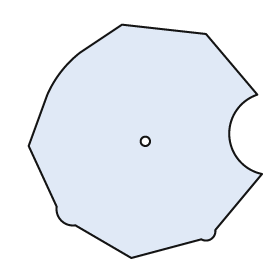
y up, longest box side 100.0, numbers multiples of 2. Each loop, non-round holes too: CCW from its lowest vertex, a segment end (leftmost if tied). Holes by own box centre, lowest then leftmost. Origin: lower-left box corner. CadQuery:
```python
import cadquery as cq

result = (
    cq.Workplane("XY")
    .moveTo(44.0, 0.0)
    .lineTo(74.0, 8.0)
    .threePointArc((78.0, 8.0), (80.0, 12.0))
    .lineTo(100.0, 36.0)
    .threePointArc((86.0, 52.0), (98.0, 70.0))
    .lineTo(76.0, 96.0)
    .lineTo(40.0, 100.0)
    .lineTo(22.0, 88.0)
    .threePointArc((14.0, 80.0), (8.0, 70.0))
    .lineTo(0.0, 48.0)
    .lineTo(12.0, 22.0)
    .threePointArc((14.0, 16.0), (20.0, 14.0))
    .close()
    .moveTo(50.0, 50.0)
    .circle(2.0)
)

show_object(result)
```